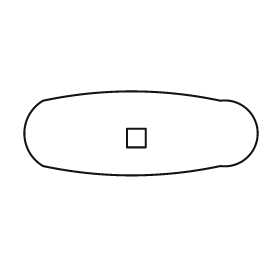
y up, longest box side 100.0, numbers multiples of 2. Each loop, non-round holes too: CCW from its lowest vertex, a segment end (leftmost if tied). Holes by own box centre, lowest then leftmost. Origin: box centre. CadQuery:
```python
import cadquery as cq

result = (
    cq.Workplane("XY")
    .moveTo(-42.0, -14.0)
    .threePointArc((-4.0, -18.0), (34.0, -14.0))
    .threePointArc((50.0, 0.0), (34.0, 14.0))
    .threePointArc((-4.0, 18.0), (-42.0, 14.0))
    .threePointArc((-50.0, 0.0), (-42.0, -14.0))
    .close()
    .moveTo(-6.0, -6.0)
    .lineTo(2.0, -6.0)
    .lineTo(2.0, 2.0)
    .lineTo(-6.0, 2.0)
    .close()
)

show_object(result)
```